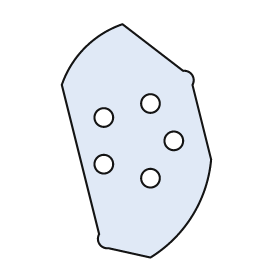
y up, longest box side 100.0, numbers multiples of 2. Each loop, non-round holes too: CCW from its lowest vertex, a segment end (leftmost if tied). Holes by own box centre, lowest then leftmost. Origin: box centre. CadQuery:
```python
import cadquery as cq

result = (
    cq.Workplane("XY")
    .moveTo(6.0, -50.0)
    .threePointArc((24.0, -32.0), (32.0, -8.0))
    .lineTo(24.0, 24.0)
    .threePointArc((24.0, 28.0), (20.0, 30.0))
    .lineTo(-6.0, 50.0)
    .threePointArc((-22.0, 40.0), (-32.0, 24.0))
    .lineTo(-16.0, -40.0)
    .threePointArc((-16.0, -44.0), (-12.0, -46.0))
    .close()
    .moveTo(6.0, -16.0)
    .circle(4.0)
    .moveTo(-14.0, -10.0)
    .circle(4.0)
    .moveTo(16.0, 0.0)
    .circle(4.0)
    .moveTo(-14.0, 10.0)
    .circle(4.0)
    .moveTo(6.0, 16.0)
    .circle(4.0)
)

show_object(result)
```